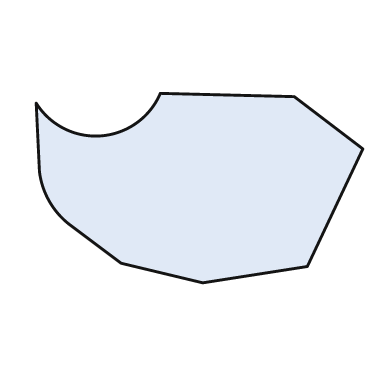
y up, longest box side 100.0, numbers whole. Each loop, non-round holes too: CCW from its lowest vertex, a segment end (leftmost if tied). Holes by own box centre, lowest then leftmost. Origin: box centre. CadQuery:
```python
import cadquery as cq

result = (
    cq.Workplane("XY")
    .moveTo(1.0, -29.0)
    .lineTo(33.0, -24.0)
    .lineTo(50.0, 12.0)
    .lineTo(29.0, 28.0)
    .lineTo(-12.0, 29.0)
    .threePointArc((-30.0, 16.0), (-50.0, 26.0))
    .lineTo(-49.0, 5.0)
    .threePointArc((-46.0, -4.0), (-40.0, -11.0))
    .lineTo(-24.0, -23.0)
    .close()
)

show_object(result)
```